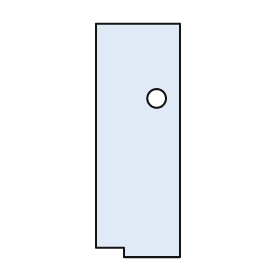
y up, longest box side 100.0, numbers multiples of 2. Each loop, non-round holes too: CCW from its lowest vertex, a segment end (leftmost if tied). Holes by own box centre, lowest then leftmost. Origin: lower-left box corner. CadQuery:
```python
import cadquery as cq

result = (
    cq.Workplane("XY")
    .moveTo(12.0, 0.0)
    .lineTo(36.0, 0.0)
    .lineTo(36.0, 100.0)
    .lineTo(0.0, 100.0)
    .lineTo(0.0, 4.0)
    .lineTo(12.0, 4.0)
    .close()
    .moveTo(26.0, 68.0)
    .circle(4.0)
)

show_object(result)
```